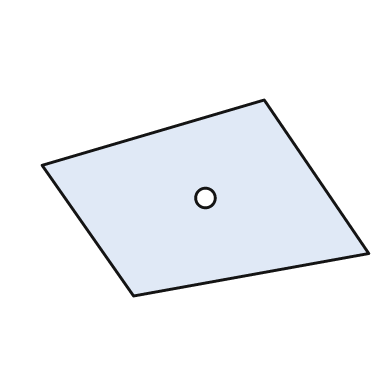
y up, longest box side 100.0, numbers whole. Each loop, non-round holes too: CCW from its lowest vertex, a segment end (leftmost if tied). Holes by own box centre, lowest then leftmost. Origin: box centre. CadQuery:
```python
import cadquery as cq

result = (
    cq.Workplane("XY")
    .moveTo(-22.0, -30.0)
    .lineTo(50.0, -17.0)
    .lineTo(18.0, 30.0)
    .lineTo(-50.0, 10.0)
    .close()
    .moveTo(0.0, 0.0)
    .circle(3.0)
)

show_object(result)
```